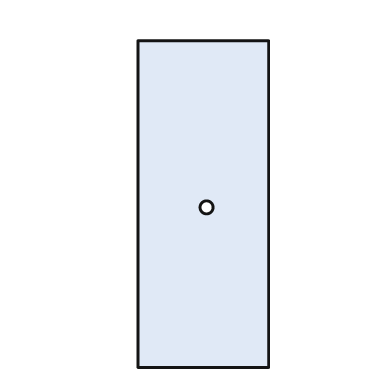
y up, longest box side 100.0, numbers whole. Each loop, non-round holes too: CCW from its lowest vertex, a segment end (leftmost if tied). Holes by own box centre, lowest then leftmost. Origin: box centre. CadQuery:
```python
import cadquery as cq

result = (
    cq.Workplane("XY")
    .moveTo(-20.0, -50.0)
    .lineTo(20.0, -50.0)
    .lineTo(20.0, 50.0)
    .lineTo(-20.0, 50.0)
    .close()
    .moveTo(1.0, -1.0)
    .circle(2.0)
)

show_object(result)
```